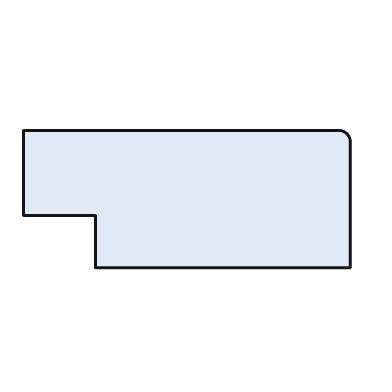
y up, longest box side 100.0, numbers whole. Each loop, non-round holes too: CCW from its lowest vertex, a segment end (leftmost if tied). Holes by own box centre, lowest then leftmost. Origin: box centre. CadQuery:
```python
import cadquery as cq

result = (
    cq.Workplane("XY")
    .moveTo(-28.0, -21.0)
    .lineTo(50.0, -21.0)
    .lineTo(50.0, 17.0)
    .threePointArc((49.0, 20.0), (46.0, 21.0))
    .lineTo(-50.0, 21.0)
    .lineTo(-50.0, -5.0)
    .lineTo(-28.0, -5.0)
    .close()
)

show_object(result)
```